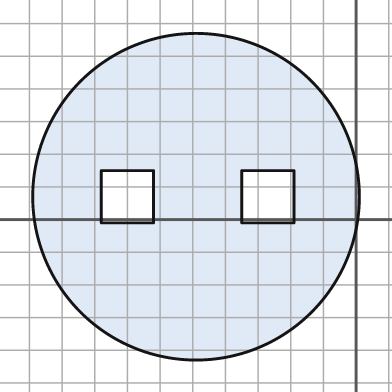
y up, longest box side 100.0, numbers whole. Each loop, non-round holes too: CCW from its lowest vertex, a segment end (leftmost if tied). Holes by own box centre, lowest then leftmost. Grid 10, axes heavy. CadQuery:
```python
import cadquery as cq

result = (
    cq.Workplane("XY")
    .moveTo(-49.0, 7.0)
    .circle(50.0)
    .moveTo(-78.0, -1.0)
    .lineTo(-62.0, -1.0)
    .lineTo(-62.0, 15.0)
    .lineTo(-78.0, 15.0)
    .close()
    .moveTo(-35.0, -1.0)
    .lineTo(-19.0, -1.0)
    .lineTo(-19.0, 15.0)
    .lineTo(-35.0, 15.0)
    .close()
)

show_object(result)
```